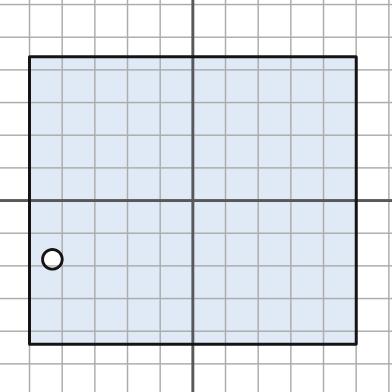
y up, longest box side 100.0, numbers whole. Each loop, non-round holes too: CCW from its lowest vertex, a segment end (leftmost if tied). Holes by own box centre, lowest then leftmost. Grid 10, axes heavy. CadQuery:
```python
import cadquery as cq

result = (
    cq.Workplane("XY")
    .moveTo(-50.0, -44.0)
    .lineTo(50.0, -44.0)
    .lineTo(50.0, 44.0)
    .lineTo(-50.0, 44.0)
    .close()
    .moveTo(-43.0, -18.0)
    .circle(3.0)
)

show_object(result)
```